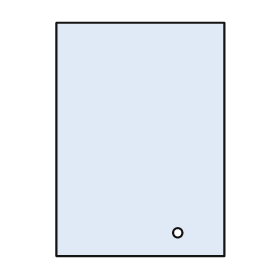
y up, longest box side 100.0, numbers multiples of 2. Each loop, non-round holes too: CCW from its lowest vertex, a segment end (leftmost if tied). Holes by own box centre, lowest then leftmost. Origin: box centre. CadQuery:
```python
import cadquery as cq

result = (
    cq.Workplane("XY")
    .moveTo(-36.0, -50.0)
    .lineTo(36.0, -50.0)
    .lineTo(36.0, 50.0)
    .lineTo(-36.0, 50.0)
    .close()
    .moveTo(16.0, -40.0)
    .circle(2.0)
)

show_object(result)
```